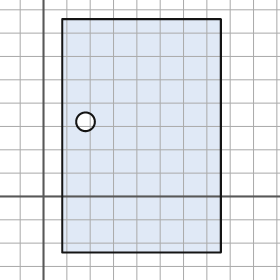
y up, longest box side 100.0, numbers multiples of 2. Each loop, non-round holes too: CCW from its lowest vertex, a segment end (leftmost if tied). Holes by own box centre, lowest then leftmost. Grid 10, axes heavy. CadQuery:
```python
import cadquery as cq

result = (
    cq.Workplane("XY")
    .moveTo(8.0, -24.0)
    .lineTo(76.0, -24.0)
    .lineTo(76.0, 76.0)
    .lineTo(8.0, 76.0)
    .close()
    .moveTo(18.0, 32.0)
    .circle(4.0)
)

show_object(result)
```